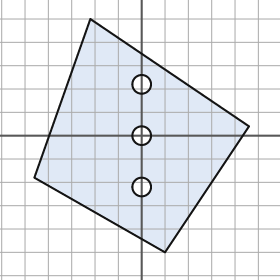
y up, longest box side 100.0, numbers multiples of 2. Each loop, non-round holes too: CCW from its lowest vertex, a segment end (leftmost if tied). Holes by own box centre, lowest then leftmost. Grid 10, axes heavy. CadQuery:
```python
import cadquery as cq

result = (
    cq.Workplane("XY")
    .moveTo(10.0, -50.0)
    .lineTo(46.0, 4.0)
    .lineTo(-22.0, 50.0)
    .lineTo(-46.0, -18.0)
    .close()
    .moveTo(0.0, -22.0)
    .circle(4.0)
    .moveTo(0.0, 0.0)
    .circle(4.0)
    .moveTo(0.0, 22.0)
    .circle(4.0)
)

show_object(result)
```